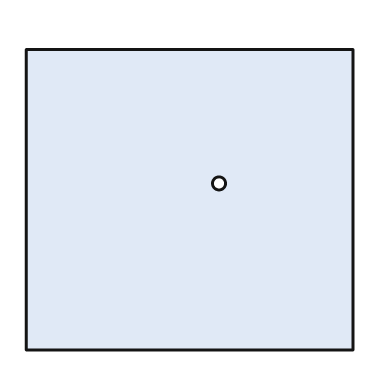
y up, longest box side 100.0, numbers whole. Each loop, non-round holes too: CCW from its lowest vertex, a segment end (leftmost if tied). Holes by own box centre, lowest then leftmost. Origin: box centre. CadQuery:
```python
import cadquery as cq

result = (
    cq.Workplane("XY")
    .moveTo(-50.0, -46.0)
    .lineTo(50.0, -46.0)
    .lineTo(50.0, 46.0)
    .lineTo(-50.0, 46.0)
    .close()
    .moveTo(9.0, 5.0)
    .circle(2.0)
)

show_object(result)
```